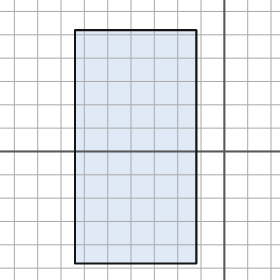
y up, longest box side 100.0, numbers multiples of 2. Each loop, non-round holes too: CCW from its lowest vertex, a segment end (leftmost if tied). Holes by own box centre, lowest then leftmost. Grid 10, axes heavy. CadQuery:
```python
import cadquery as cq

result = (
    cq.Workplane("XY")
    .moveTo(-64.0, -48.0)
    .lineTo(-12.0, -48.0)
    .lineTo(-12.0, 52.0)
    .lineTo(-64.0, 52.0)
    .close()
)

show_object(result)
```